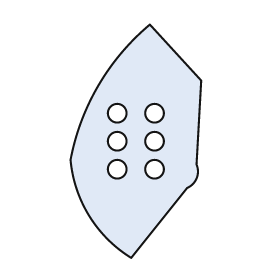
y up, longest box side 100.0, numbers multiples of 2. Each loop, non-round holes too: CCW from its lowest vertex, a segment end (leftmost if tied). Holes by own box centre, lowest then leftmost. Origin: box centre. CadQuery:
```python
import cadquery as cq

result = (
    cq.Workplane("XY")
    .moveTo(-2.0, -50.0)
    .lineTo(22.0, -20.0)
    .threePointArc((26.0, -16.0), (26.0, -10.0))
    .lineTo(28.0, 26.0)
    .lineTo(6.0, 50.0)
    .threePointArc((-16.0, 24.0), (-28.0, -8.0))
    .threePointArc((-20.0, -32.0), (-2.0, -50.0))
    .close()
    .moveTo(-8.0, -12.0)
    .circle(4.0)
    .moveTo(8.0, -12.0)
    .circle(4.0)
    .moveTo(-8.0, 0.0)
    .circle(4.0)
    .moveTo(8.0, 0.0)
    .circle(4.0)
    .moveTo(-8.0, 12.0)
    .circle(4.0)
    .moveTo(8.0, 12.0)
    .circle(4.0)
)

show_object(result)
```